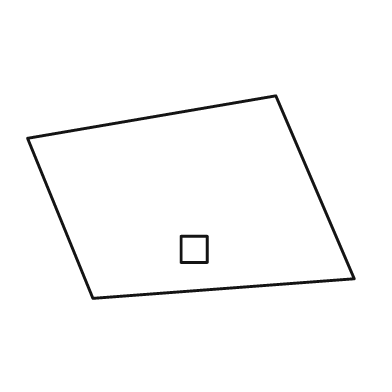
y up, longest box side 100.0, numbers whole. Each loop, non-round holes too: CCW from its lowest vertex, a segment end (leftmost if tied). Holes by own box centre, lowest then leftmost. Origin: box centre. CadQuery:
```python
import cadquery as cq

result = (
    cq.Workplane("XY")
    .moveTo(-30.0, -31.0)
    .lineTo(50.0, -25.0)
    .lineTo(26.0, 31.0)
    .lineTo(-50.0, 18.0)
    .close()
    .moveTo(-3.0, -20.0)
    .lineTo(5.0, -20.0)
    .lineTo(5.0, -12.0)
    .lineTo(-3.0, -12.0)
    .close()
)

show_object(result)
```